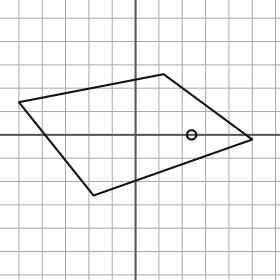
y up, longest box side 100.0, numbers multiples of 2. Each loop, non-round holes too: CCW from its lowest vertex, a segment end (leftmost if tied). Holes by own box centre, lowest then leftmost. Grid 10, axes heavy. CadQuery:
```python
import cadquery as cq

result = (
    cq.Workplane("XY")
    .moveTo(-18.0, -26.0)
    .lineTo(50.0, -2.0)
    .lineTo(12.0, 26.0)
    .lineTo(-50.0, 14.0)
    .close()
    .moveTo(24.0, 0.0)
    .circle(2.0)
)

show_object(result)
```